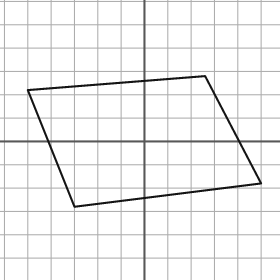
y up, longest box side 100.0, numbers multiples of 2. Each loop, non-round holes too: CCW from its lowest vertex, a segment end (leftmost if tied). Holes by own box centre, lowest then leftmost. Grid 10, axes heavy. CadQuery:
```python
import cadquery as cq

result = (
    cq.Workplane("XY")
    .moveTo(-30.0, -28.0)
    .lineTo(50.0, -18.0)
    .lineTo(26.0, 28.0)
    .lineTo(-50.0, 22.0)
    .close()
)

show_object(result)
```